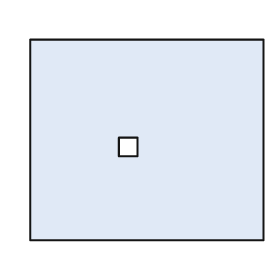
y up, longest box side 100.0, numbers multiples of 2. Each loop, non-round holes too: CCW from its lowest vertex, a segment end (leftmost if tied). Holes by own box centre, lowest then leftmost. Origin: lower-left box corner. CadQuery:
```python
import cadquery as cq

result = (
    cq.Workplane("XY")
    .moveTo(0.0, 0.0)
    .lineTo(100.0, 0.0)
    .lineTo(100.0, 86.0)
    .lineTo(0.0, 86.0)
    .close()
    .moveTo(38.0, 36.0)
    .lineTo(46.0, 36.0)
    .lineTo(46.0, 44.0)
    .lineTo(38.0, 44.0)
    .close()
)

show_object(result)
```